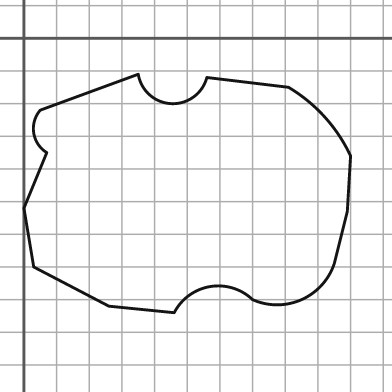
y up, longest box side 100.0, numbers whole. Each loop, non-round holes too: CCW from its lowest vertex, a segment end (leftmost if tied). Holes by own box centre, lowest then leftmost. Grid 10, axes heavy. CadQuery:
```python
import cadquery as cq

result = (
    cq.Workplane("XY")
    .moveTo(46.0, -84.0)
    .threePointArc((57.0, -76.0), (70.0, -80.0))
    .threePointArc((85.0, -80.0), (95.0, -69.0))
    .lineTo(99.0, -53.0)
    .lineTo(100.0, -36.0)
    .threePointArc((92.0, -24.0), (81.0, -15.0))
    .lineTo(56.0, -12.0)
    .threePointArc((45.0, -20.0), (35.0, -11.0))
    .lineTo(5.0, -22.0)
    .threePointArc((3.0, -29.0), (7.0, -35.0))
    .lineTo(0.0, -52.0)
    .lineTo(3.0, -70.0)
    .lineTo(26.0, -82.0)
    .close()
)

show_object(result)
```